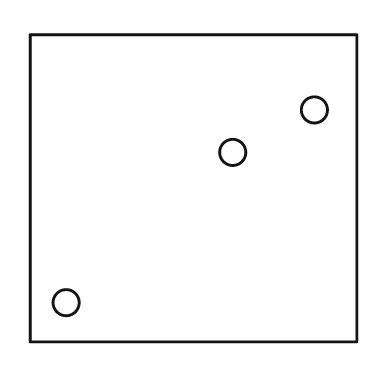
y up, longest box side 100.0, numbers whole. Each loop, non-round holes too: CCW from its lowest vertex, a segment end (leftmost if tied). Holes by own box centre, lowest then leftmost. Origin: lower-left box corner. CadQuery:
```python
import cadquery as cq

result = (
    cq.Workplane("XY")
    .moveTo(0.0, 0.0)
    .lineTo(100.0, 0.0)
    .lineTo(100.0, 94.0)
    .lineTo(0.0, 94.0)
    .close()
    .moveTo(11.0, 12.0)
    .circle(4.0)
    .moveTo(62.0, 58.0)
    .circle(4.0)
    .moveTo(87.0, 71.0)
    .circle(4.0)
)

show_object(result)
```